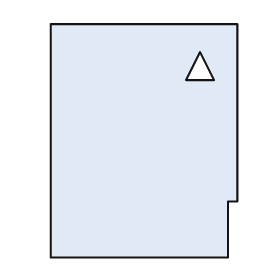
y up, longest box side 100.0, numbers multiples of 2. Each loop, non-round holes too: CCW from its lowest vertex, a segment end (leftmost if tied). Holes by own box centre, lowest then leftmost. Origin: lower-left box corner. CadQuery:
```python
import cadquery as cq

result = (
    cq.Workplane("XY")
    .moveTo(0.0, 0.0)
    .lineTo(76.0, 0.0)
    .lineTo(76.0, 24.0)
    .lineTo(80.0, 24.0)
    .lineTo(80.0, 100.0)
    .lineTo(0.0, 100.0)
    .close()
    .moveTo(58.0, 76.0)
    .lineTo(70.0, 76.0)
    .lineTo(64.0, 88.0)
    .close()
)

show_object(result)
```